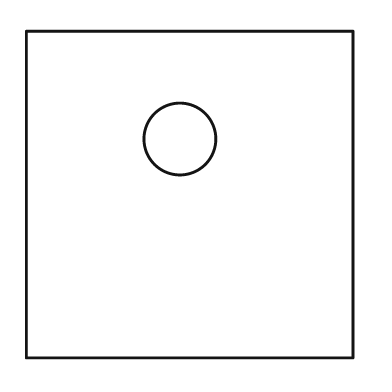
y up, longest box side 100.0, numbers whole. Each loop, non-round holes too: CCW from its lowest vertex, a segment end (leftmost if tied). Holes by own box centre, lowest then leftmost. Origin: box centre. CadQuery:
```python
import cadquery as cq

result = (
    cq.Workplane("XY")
    .moveTo(-50.0, -50.0)
    .lineTo(50.0, -50.0)
    .lineTo(50.0, 50.0)
    .lineTo(-50.0, 50.0)
    .close()
    .moveTo(-3.0, 17.0)
    .circle(11.0)
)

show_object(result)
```